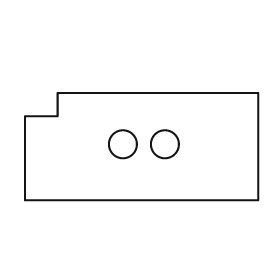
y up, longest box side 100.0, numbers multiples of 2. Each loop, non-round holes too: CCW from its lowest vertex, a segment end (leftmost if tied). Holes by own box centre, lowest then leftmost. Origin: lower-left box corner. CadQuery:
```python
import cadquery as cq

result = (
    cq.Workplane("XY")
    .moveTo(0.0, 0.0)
    .lineTo(100.0, 0.0)
    .lineTo(100.0, 46.0)
    .lineTo(14.0, 46.0)
    .lineTo(14.0, 36.0)
    .lineTo(0.0, 36.0)
    .close()
    .moveTo(42.0, 24.0)
    .circle(6.0)
    .moveTo(60.0, 24.0)
    .circle(6.0)
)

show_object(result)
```